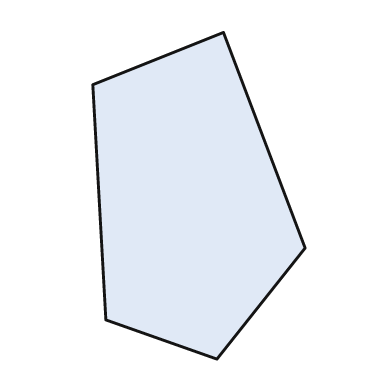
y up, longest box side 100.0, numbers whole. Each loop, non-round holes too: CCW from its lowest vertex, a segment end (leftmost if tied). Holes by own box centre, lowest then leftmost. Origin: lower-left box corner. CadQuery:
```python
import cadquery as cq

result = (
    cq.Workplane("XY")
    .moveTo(38.0, 0.0)
    .lineTo(65.0, 34.0)
    .lineTo(40.0, 100.0)
    .lineTo(0.0, 84.0)
    .lineTo(4.0, 12.0)
    .close()
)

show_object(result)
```